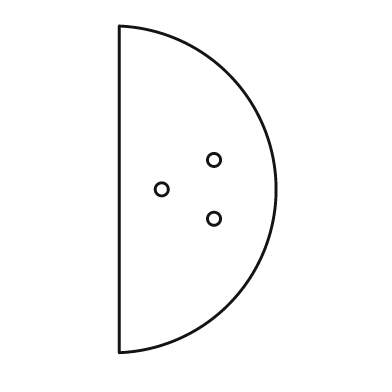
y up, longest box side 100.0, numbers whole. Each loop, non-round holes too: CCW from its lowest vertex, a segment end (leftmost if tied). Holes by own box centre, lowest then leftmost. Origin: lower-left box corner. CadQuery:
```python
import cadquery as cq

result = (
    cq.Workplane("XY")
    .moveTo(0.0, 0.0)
    .threePointArc((48.0, 50.0), (0.0, 100.0))
    .close()
    .moveTo(29.0, 41.0)
    .circle(2.0)
    .moveTo(13.0, 50.0)
    .circle(2.0)
    .moveTo(29.0, 59.0)
    .circle(2.0)
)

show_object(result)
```